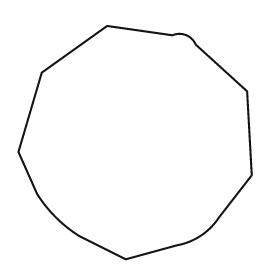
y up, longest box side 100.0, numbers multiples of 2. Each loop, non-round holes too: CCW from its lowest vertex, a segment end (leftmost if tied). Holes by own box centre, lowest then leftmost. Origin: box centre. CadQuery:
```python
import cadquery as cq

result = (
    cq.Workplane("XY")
    .moveTo(-4.0, -50.0)
    .lineTo(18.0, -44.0)
    .threePointArc((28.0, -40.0), (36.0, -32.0))
    .lineTo(50.0, -14.0)
    .lineTo(48.0, 22.0)
    .lineTo(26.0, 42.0)
    .threePointArc((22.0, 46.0), (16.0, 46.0))
    .lineTo(-12.0, 50.0)
    .lineTo(-40.0, 30.0)
    .lineTo(-50.0, -4.0)
    .lineTo(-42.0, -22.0)
    .threePointArc((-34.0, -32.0), (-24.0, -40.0))
    .close()
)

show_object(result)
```